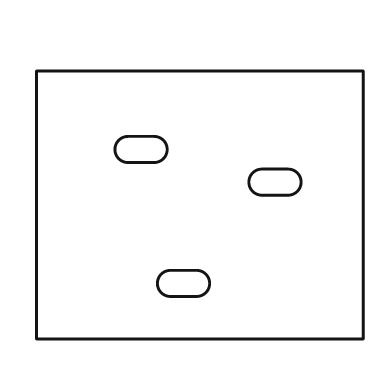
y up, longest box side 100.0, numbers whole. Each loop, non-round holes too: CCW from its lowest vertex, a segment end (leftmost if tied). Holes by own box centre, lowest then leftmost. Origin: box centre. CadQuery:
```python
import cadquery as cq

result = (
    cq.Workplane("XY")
    .moveTo(-50.0, -41.0)
    .lineTo(50.0, -41.0)
    .lineTo(50.0, 41.0)
    .lineTo(-50.0, 41.0)
    .close()
    .moveTo(-9.0, -28.0)
    .lineTo(-1.0, -28.0)
    .threePointArc((3.0, -24.0), (-1.0, -20.0))
    .lineTo(-9.0, -20.0)
    .threePointArc((-13.0, -24.0), (-9.0, -28.0))
    .close()
    .moveTo(19.0, 3.0)
    .lineTo(27.0, 3.0)
    .threePointArc((31.0, 7.0), (27.0, 11.0))
    .lineTo(19.0, 11.0)
    .threePointArc((15.0, 7.0), (19.0, 3.0))
    .close()
    .moveTo(-22.0, 13.0)
    .lineTo(-14.0, 13.0)
    .threePointArc((-10.0, 17.0), (-14.0, 21.0))
    .lineTo(-22.0, 21.0)
    .threePointArc((-26.0, 17.0), (-22.0, 13.0))
    .close()
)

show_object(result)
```